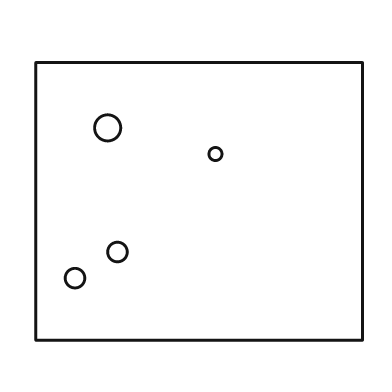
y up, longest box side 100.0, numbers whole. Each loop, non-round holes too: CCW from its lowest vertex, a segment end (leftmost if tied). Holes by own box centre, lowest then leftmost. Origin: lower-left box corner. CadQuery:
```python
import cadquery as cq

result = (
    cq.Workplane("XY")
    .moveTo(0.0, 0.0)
    .lineTo(100.0, 0.0)
    .lineTo(100.0, 85.0)
    .lineTo(0.0, 85.0)
    .close()
    .moveTo(12.0, 19.0)
    .circle(3.0)
    .moveTo(25.0, 27.0)
    .circle(3.0)
    .moveTo(55.0, 57.0)
    .circle(2.0)
    .moveTo(22.0, 65.0)
    .circle(4.0)
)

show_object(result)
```